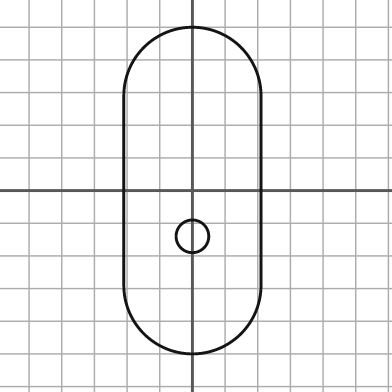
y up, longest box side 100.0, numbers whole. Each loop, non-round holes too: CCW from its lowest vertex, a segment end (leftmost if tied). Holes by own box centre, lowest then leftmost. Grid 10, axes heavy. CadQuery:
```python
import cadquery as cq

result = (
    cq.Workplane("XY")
    .moveTo(-21.0, -29.0)
    .threePointArc((0.0, -50.0), (21.0, -29.0))
    .lineTo(21.0, 29.0)
    .threePointArc((0.0, 50.0), (-21.0, 29.0))
    .close()
    .moveTo(0.0, -14.0)
    .circle(5.0)
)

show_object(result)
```